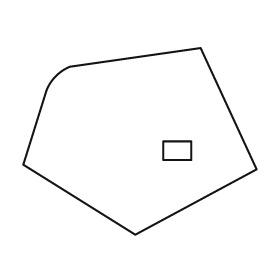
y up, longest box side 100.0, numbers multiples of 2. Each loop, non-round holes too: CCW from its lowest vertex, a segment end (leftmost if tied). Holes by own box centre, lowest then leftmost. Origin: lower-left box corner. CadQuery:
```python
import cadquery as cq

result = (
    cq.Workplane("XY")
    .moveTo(48.0, 0.0)
    .lineTo(100.0, 28.0)
    .lineTo(76.0, 80.0)
    .lineTo(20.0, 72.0)
    .threePointArc((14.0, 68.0), (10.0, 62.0))
    .lineTo(0.0, 30.0)
    .close()
    .moveTo(60.0, 32.0)
    .lineTo(72.0, 32.0)
    .lineTo(72.0, 40.0)
    .lineTo(60.0, 40.0)
    .close()
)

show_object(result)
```